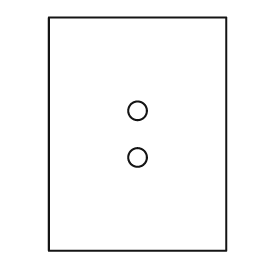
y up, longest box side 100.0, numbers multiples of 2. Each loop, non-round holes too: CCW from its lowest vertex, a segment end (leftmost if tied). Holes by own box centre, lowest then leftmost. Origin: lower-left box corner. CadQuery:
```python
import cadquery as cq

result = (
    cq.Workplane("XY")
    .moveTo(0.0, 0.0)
    .lineTo(76.0, 0.0)
    .lineTo(76.0, 100.0)
    .lineTo(0.0, 100.0)
    .close()
    .moveTo(38.0, 40.0)
    .circle(4.0)
    .moveTo(38.0, 60.0)
    .circle(4.0)
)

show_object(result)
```